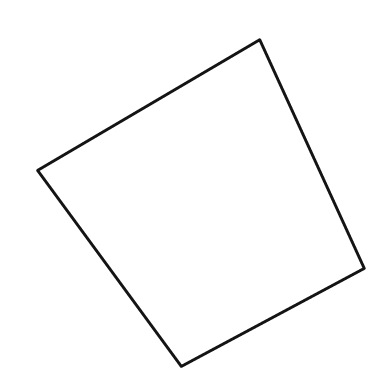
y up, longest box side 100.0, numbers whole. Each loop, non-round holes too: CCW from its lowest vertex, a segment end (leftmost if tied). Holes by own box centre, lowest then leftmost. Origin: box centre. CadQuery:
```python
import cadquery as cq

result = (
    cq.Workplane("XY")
    .moveTo(-6.0, -50.0)
    .lineTo(50.0, -20.0)
    .lineTo(18.0, 50.0)
    .lineTo(-50.0, 10.0)
    .close()
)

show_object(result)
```